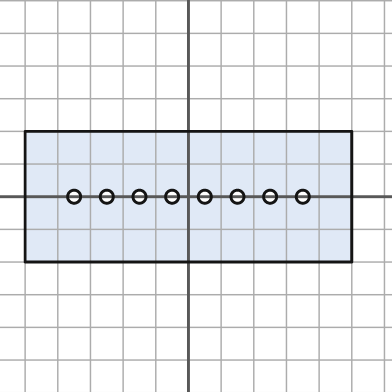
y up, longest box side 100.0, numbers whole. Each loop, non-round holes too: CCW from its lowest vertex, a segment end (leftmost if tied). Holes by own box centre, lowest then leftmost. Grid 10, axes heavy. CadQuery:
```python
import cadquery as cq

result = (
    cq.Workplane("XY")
    .moveTo(-50.0, -20.0)
    .lineTo(50.0, -20.0)
    .lineTo(50.0, 20.0)
    .lineTo(-50.0, 20.0)
    .close()
    .moveTo(-35.0, 0.0)
    .circle(2.0)
    .moveTo(-25.0, 0.0)
    .circle(2.0)
    .moveTo(-15.0, 0.0)
    .circle(2.0)
    .moveTo(-5.0, 0.0)
    .circle(2.0)
    .moveTo(5.0, 0.0)
    .circle(2.0)
    .moveTo(15.0, 0.0)
    .circle(2.0)
    .moveTo(25.0, 0.0)
    .circle(2.0)
    .moveTo(35.0, 0.0)
    .circle(2.0)
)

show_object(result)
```